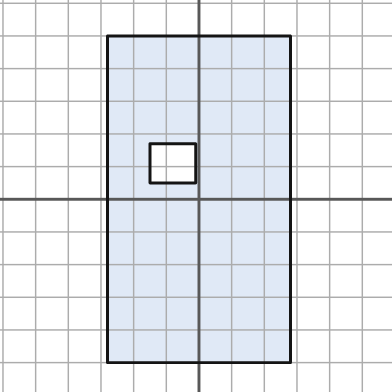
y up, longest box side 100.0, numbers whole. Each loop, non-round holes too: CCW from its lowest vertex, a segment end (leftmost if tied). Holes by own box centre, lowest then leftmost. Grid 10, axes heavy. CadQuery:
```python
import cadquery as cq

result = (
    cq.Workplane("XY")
    .moveTo(-28.0, -50.0)
    .lineTo(28.0, -50.0)
    .lineTo(28.0, 50.0)
    .lineTo(-28.0, 50.0)
    .close()
    .moveTo(-15.0, 5.0)
    .lineTo(-1.0, 5.0)
    .lineTo(-1.0, 17.0)
    .lineTo(-15.0, 17.0)
    .close()
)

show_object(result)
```